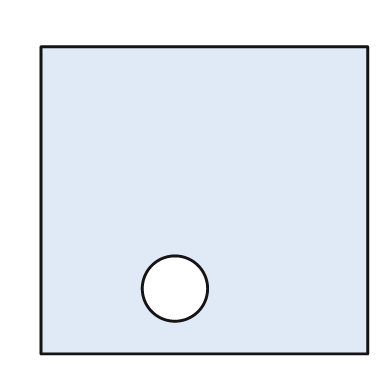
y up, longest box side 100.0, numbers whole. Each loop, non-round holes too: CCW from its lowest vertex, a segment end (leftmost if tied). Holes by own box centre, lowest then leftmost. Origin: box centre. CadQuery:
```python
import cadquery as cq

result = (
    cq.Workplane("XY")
    .moveTo(-50.0, -47.0)
    .lineTo(50.0, -47.0)
    .lineTo(50.0, 47.0)
    .lineTo(-50.0, 47.0)
    .close()
    .moveTo(-9.0, -27.0)
    .circle(10.0)
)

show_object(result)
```